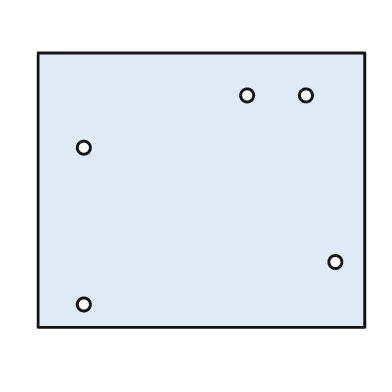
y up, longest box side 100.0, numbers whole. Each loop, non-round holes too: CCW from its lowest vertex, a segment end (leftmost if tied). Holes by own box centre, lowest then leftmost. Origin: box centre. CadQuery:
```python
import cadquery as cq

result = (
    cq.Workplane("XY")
    .moveTo(-50.0, -42.0)
    .lineTo(50.0, -42.0)
    .lineTo(50.0, 42.0)
    .lineTo(-50.0, 42.0)
    .close()
    .moveTo(-36.0, -35.0)
    .circle(2.0)
    .moveTo(41.0, -22.0)
    .circle(2.0)
    .moveTo(-36.0, 13.0)
    .circle(2.0)
    .moveTo(14.0, 29.0)
    .circle(2.0)
    .moveTo(32.0, 29.0)
    .circle(2.0)
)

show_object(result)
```